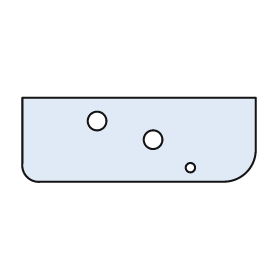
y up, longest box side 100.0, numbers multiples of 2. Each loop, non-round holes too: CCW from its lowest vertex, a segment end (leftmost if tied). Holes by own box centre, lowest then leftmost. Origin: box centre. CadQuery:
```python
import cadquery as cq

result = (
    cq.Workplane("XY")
    .moveTo(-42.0, -18.0)
    .lineTo(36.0, -18.0)
    .threePointArc((46.0, -14.0), (50.0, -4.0))
    .lineTo(50.0, 18.0)
    .lineTo(-50.0, 18.0)
    .lineTo(-50.0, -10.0)
    .threePointArc((-48.0, -16.0), (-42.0, -18.0))
    .close()
    .moveTo(22.0, -12.0)
    .circle(2.0)
    .moveTo(6.0, 0.0)
    .circle(4.0)
    .moveTo(-18.0, 8.0)
    .circle(4.0)
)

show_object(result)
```